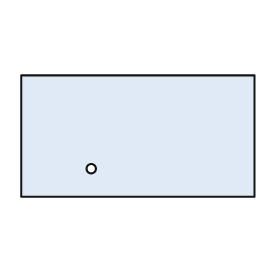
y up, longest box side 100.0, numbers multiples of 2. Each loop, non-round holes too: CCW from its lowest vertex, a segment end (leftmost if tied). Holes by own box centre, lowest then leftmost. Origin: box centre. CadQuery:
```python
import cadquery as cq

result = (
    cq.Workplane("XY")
    .moveTo(-50.0, -26.0)
    .lineTo(50.0, -26.0)
    .lineTo(50.0, 26.0)
    .lineTo(-50.0, 26.0)
    .close()
    .moveTo(-20.0, -14.0)
    .circle(2.0)
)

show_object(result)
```